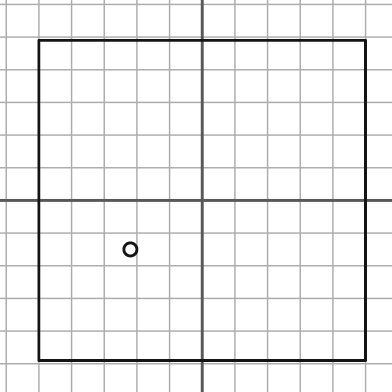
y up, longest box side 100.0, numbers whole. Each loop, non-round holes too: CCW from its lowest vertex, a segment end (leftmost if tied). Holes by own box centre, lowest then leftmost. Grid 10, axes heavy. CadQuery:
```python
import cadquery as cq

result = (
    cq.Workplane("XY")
    .moveTo(-50.0, -49.0)
    .lineTo(50.0, -49.0)
    .lineTo(50.0, 49.0)
    .lineTo(-50.0, 49.0)
    .close()
    .moveTo(-22.0, -15.0)
    .circle(2.0)
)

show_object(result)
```